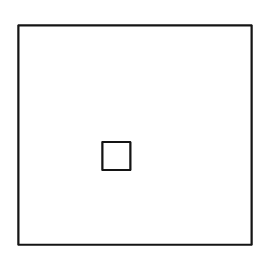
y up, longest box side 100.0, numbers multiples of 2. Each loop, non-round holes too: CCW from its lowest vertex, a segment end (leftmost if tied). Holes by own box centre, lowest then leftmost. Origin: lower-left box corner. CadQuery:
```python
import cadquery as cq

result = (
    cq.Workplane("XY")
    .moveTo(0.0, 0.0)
    .lineTo(100.0, 0.0)
    .lineTo(100.0, 94.0)
    .lineTo(0.0, 94.0)
    .close()
    .moveTo(36.0, 32.0)
    .lineTo(48.0, 32.0)
    .lineTo(48.0, 44.0)
    .lineTo(36.0, 44.0)
    .close()
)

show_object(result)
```